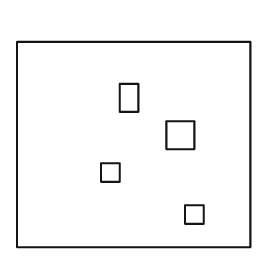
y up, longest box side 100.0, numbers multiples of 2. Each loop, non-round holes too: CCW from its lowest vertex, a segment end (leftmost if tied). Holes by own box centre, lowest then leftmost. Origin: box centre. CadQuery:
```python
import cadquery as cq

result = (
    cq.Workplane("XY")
    .moveTo(-50.0, -44.0)
    .lineTo(50.0, -44.0)
    .lineTo(50.0, 44.0)
    .lineTo(-50.0, 44.0)
    .close()
    .moveTo(22.0, -34.0)
    .lineTo(30.0, -34.0)
    .lineTo(30.0, -26.0)
    .lineTo(22.0, -26.0)
    .close()
    .moveTo(-14.0, -16.0)
    .lineTo(-6.0, -16.0)
    .lineTo(-6.0, -8.0)
    .lineTo(-14.0, -8.0)
    .close()
    .moveTo(14.0, -2.0)
    .lineTo(26.0, -2.0)
    .lineTo(26.0, 10.0)
    .lineTo(14.0, 10.0)
    .close()
    .moveTo(-6.0, 14.0)
    .lineTo(2.0, 14.0)
    .lineTo(2.0, 26.0)
    .lineTo(-6.0, 26.0)
    .close()
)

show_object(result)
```